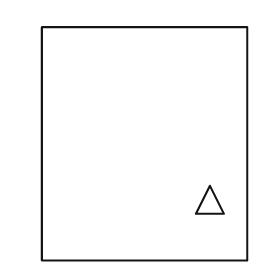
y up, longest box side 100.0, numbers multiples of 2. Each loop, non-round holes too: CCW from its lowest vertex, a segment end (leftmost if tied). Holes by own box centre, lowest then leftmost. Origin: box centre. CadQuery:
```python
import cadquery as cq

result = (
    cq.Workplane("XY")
    .moveTo(-44.0, -50.0)
    .lineTo(44.0, -50.0)
    .lineTo(44.0, 50.0)
    .lineTo(-44.0, 50.0)
    .close()
    .moveTo(22.0, -30.0)
    .lineTo(34.0, -30.0)
    .lineTo(28.0, -18.0)
    .close()
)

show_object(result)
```